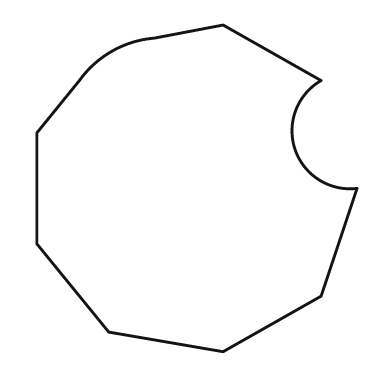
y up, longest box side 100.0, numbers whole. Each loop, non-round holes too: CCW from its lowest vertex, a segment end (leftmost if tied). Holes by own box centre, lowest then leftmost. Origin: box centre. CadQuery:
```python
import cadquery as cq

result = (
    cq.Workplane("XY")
    .moveTo(8.0, -50.0)
    .lineTo(38.0, -33.0)
    .lineTo(49.0, 0.0)
    .threePointArc((30.0, 12.0), (38.0, 33.0))
    .lineTo(8.0, 50.0)
    .lineTo(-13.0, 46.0)
    .threePointArc((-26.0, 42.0), (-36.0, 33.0))
    .lineTo(-49.0, 17.0)
    .lineTo(-49.0, -17.0)
    .lineTo(-27.0, -44.0)
    .close()
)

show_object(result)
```